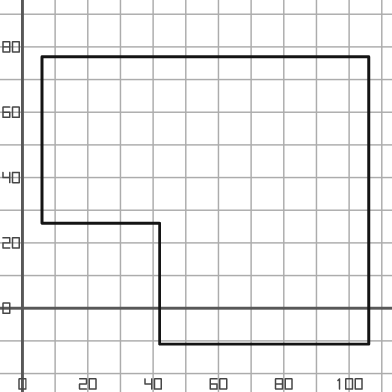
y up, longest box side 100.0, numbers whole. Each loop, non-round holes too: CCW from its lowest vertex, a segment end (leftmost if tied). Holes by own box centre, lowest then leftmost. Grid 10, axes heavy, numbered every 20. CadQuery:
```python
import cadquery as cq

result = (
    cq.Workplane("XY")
    .moveTo(42.0, -11.0)
    .lineTo(106.0, -11.0)
    .lineTo(106.0, 77.0)
    .lineTo(6.0, 77.0)
    .lineTo(6.0, 26.0)
    .lineTo(42.0, 26.0)
    .close()
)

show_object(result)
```